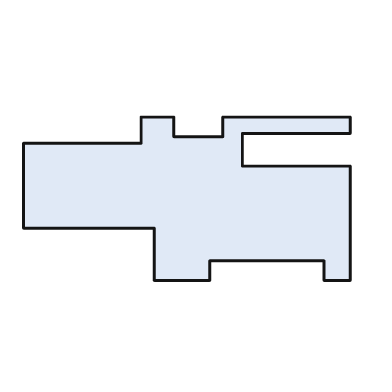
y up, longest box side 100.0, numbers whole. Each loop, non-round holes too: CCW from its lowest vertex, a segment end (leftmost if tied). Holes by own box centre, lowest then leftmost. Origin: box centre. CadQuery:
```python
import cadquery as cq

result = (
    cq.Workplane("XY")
    .moveTo(-10.0, -25.0)
    .lineTo(7.0, -25.0)
    .lineTo(7.0, -19.0)
    .lineTo(42.0, -19.0)
    .lineTo(42.0, -25.0)
    .lineTo(50.0, -25.0)
    .lineTo(50.0, 10.0)
    .lineTo(17.0, 10.0)
    .lineTo(17.0, 20.0)
    .lineTo(50.0, 20.0)
    .lineTo(50.0, 25.0)
    .lineTo(11.0, 25.0)
    .lineTo(11.0, 19.0)
    .lineTo(-4.0, 19.0)
    .lineTo(-4.0, 25.0)
    .lineTo(-14.0, 25.0)
    .lineTo(-14.0, 17.0)
    .lineTo(-50.0, 17.0)
    .lineTo(-50.0, -9.0)
    .lineTo(-10.0, -9.0)
    .close()
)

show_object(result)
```